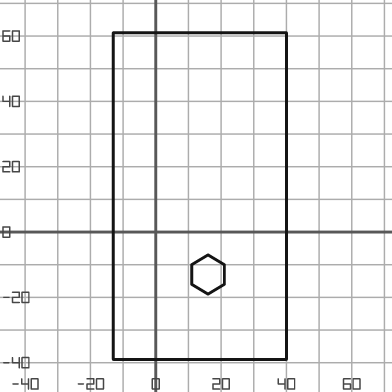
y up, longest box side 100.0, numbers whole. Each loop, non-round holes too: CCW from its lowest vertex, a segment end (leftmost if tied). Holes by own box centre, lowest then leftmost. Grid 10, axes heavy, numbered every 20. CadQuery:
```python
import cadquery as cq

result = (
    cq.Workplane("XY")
    .moveTo(-13.0, -39.0)
    .lineTo(40.0, -39.0)
    .lineTo(40.0, 61.0)
    .lineTo(-13.0, 61.0)
    .close()
    .moveTo(16.0, -19.0)
    .lineTo(21.0, -16.0)
    .lineTo(21.0, -10.0)
    .lineTo(16.0, -7.0)
    .lineTo(11.0, -10.0)
    .lineTo(11.0, -16.0)
    .close()
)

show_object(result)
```